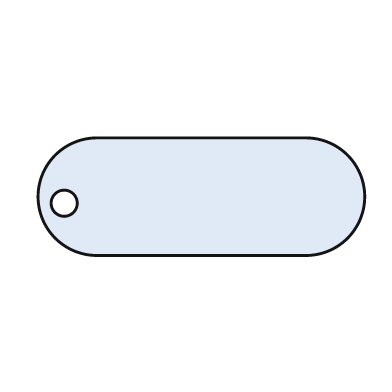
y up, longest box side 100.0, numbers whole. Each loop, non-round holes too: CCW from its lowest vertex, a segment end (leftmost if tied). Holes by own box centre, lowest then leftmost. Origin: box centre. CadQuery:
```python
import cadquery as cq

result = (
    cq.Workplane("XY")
    .moveTo(-32.0, -18.0)
    .lineTo(32.0, -18.0)
    .threePointArc((50.0, 0.0), (32.0, 18.0))
    .lineTo(-32.0, 18.0)
    .threePointArc((-50.0, 0.0), (-32.0, -18.0))
    .close()
    .moveTo(-42.0, -2.0)
    .circle(4.0)
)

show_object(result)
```